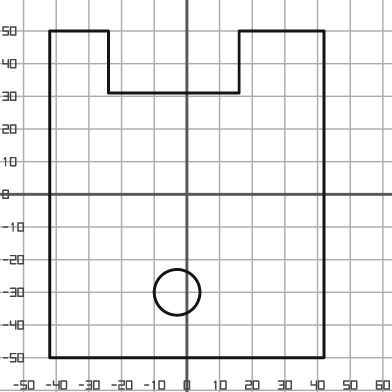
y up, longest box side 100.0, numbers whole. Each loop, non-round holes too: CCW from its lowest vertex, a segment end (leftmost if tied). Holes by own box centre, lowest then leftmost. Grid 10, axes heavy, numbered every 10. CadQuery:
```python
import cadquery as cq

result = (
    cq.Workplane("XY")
    .moveTo(-42.0, -50.0)
    .lineTo(42.0, -50.0)
    .lineTo(42.0, 50.0)
    .lineTo(16.0, 50.0)
    .lineTo(16.0, 31.0)
    .lineTo(-24.0, 31.0)
    .lineTo(-24.0, 50.0)
    .lineTo(-42.0, 50.0)
    .close()
    .moveTo(-3.0, -30.0)
    .circle(7.0)
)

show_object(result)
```